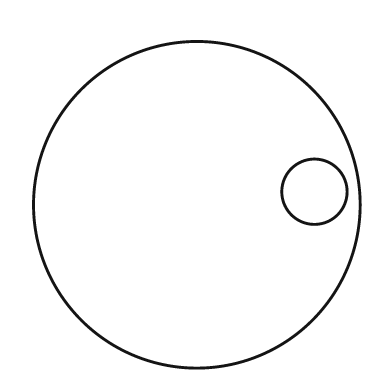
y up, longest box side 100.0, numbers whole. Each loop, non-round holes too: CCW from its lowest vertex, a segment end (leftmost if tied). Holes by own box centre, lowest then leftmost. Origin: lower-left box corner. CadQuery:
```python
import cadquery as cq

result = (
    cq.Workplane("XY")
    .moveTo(50.0, 50.0)
    .circle(50.0)
    .moveTo(86.0, 54.0)
    .circle(10.0)
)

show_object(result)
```